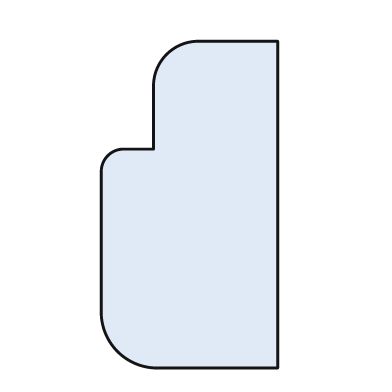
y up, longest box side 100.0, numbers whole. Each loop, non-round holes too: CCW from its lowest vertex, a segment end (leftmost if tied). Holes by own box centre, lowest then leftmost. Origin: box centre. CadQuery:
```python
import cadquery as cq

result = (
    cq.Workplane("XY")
    .moveTo(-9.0, -50.0)
    .lineTo(27.0, -50.0)
    .lineTo(27.0, 50.0)
    .lineTo(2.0, 50.0)
    .threePointArc((-7.0, 46.0), (-11.0, 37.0))
    .lineTo(-11.0, 17.0)
    .lineTo(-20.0, 17.0)
    .threePointArc((-25.0, 15.0), (-27.0, 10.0))
    .lineTo(-27.0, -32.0)
    .threePointArc((-22.0, -45.0), (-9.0, -50.0))
    .close()
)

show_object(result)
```